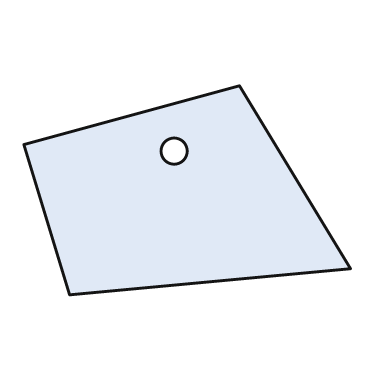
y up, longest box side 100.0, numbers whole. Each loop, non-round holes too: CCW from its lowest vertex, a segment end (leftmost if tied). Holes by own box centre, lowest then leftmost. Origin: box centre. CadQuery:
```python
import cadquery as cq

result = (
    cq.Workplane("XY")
    .moveTo(-36.0, -32.0)
    .lineTo(50.0, -24.0)
    .lineTo(16.0, 32.0)
    .lineTo(-50.0, 14.0)
    .close()
    .moveTo(-4.0, 12.0)
    .circle(4.0)
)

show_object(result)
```